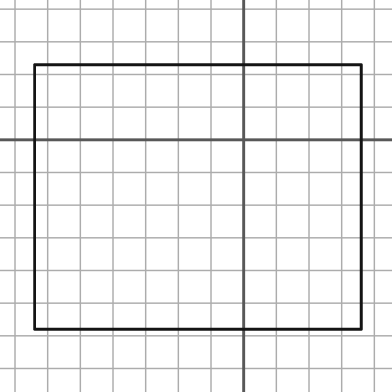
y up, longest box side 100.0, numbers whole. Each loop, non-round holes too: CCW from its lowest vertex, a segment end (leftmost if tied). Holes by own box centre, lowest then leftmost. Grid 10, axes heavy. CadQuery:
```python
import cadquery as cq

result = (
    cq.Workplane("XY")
    .moveTo(-64.0, -58.0)
    .lineTo(36.0, -58.0)
    .lineTo(36.0, 23.0)
    .lineTo(-64.0, 23.0)
    .close()
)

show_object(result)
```